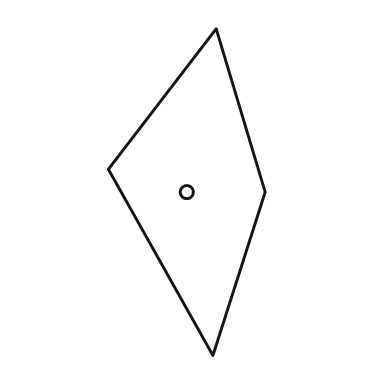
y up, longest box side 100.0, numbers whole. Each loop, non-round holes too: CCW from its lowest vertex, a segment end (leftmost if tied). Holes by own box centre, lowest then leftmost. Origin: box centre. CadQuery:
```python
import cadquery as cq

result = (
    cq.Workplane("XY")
    .moveTo(8.0, -50.0)
    .lineTo(24.0, 0.0)
    .lineTo(9.0, 50.0)
    .lineTo(-24.0, 7.0)
    .close()
    .moveTo(0.0, 0.0)
    .circle(2.0)
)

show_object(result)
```